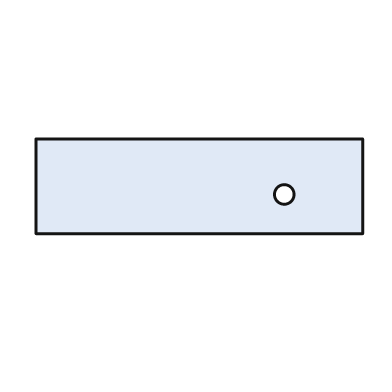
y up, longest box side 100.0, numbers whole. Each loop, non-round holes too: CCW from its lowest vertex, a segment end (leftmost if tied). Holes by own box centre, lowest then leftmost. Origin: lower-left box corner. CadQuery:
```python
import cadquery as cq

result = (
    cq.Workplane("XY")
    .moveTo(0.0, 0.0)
    .lineTo(100.0, 0.0)
    .lineTo(100.0, 29.0)
    .lineTo(0.0, 29.0)
    .close()
    .moveTo(76.0, 12.0)
    .circle(3.0)
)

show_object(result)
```